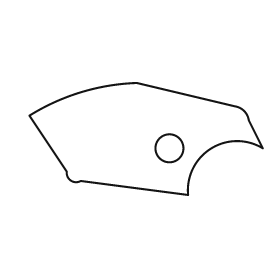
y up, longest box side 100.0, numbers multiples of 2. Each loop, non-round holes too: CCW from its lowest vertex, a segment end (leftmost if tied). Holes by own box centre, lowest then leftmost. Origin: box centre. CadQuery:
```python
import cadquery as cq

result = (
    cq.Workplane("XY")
    .moveTo(18.0, -24.0)
    .threePointArc((28.0, -4.0), (50.0, -4.0))
    .lineTo(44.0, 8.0)
    .threePointArc((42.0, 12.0), (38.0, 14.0))
    .lineTo(-4.0, 24.0)
    .threePointArc((-28.0, 20.0), (-50.0, 10.0))
    .lineTo(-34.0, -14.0)
    .threePointArc((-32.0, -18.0), (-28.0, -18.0))
    .close()
    .moveTo(10.0, -4.0)
    .circle(6.0)
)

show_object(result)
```